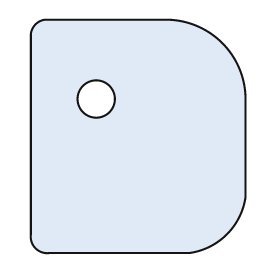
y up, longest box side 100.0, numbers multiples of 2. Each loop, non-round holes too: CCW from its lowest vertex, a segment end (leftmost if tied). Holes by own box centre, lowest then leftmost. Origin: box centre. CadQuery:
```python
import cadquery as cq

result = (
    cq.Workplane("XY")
    .moveTo(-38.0, -50.0)
    .lineTo(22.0, -50.0)
    .threePointArc((38.0, -42.0), (46.0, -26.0))
    .lineTo(46.0, 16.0)
    .threePointArc((36.0, 40.0), (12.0, 50.0))
    .lineTo(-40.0, 50.0)
    .threePointArc((-44.0, 48.0), (-46.0, 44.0))
    .lineTo(-46.0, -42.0)
    .threePointArc((-44.0, -48.0), (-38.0, -50.0))
    .close()
    .moveTo(-18.0, 16.0)
    .circle(8.0)
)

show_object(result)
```